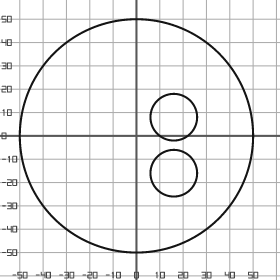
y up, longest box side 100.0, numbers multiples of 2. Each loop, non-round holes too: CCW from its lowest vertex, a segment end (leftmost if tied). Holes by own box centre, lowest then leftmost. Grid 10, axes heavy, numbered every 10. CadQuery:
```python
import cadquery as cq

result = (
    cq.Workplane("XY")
    .moveTo(0.0, 0.0)
    .circle(50.0)
    .moveTo(16.0, -16.0)
    .circle(10.0)
    .moveTo(16.0, 8.0)
    .circle(10.0)
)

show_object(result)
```